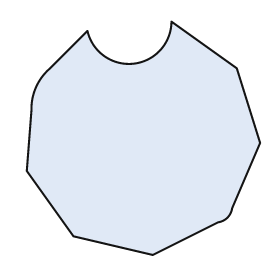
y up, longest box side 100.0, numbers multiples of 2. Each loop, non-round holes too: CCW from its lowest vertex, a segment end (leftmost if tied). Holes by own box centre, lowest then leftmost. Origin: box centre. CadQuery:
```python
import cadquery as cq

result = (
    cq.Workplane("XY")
    .moveTo(4.0, -50.0)
    .lineTo(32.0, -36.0)
    .threePointArc((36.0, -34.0), (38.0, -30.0))
    .lineTo(50.0, -2.0)
    .lineTo(40.0, 30.0)
    .lineTo(12.0, 50.0)
    .threePointArc((-4.0, 32.0), (-24.0, 46.0))
    .lineTo(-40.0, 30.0)
    .threePointArc((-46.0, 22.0), (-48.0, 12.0))
    .lineTo(-50.0, -14.0)
    .lineTo(-30.0, -42.0)
    .close()
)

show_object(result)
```